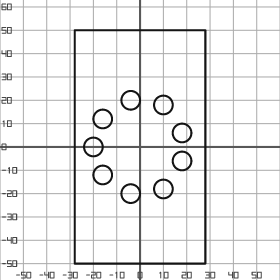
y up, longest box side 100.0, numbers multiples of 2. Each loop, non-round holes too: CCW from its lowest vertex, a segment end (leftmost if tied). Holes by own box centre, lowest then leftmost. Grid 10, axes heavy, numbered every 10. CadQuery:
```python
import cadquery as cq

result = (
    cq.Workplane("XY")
    .moveTo(-28.0, -50.0)
    .lineTo(28.0, -50.0)
    .lineTo(28.0, 50.0)
    .lineTo(-28.0, 50.0)
    .close()
    .moveTo(-4.0, -20.0)
    .circle(4.0)
    .moveTo(10.0, -18.0)
    .circle(4.0)
    .moveTo(-16.0, -12.0)
    .circle(4.0)
    .moveTo(18.0, -6.0)
    .circle(4.0)
    .moveTo(-20.0, 0.0)
    .circle(4.0)
    .moveTo(18.0, 6.0)
    .circle(4.0)
    .moveTo(-16.0, 12.0)
    .circle(4.0)
    .moveTo(10.0, 18.0)
    .circle(4.0)
    .moveTo(-4.0, 20.0)
    .circle(4.0)
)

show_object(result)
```